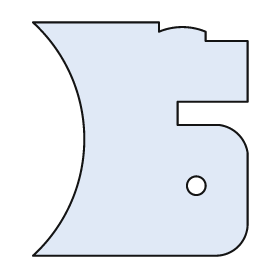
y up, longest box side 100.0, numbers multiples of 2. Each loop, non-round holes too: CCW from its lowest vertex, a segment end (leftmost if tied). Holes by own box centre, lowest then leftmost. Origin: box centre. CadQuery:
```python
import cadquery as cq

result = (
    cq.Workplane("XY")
    .moveTo(-46.0, -50.0)
    .lineTo(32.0, -50.0)
    .threePointArc((42.0, -46.0), (46.0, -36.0))
    .lineTo(46.0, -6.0)
    .threePointArc((42.0, 2.0), (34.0, 6.0))
    .lineTo(16.0, 6.0)
    .lineTo(16.0, 16.0)
    .lineTo(46.0, 16.0)
    .lineTo(46.0, 42.0)
    .lineTo(28.0, 42.0)
    .lineTo(28.0, 46.0)
    .threePointArc((18.0, 48.0), (8.0, 46.0))
    .lineTo(8.0, 50.0)
    .lineTo(-46.0, 50.0)
    .threePointArc((-24.0, 0.0), (-46.0, -50.0))
    .close()
    .moveTo(24.0, -20.0)
    .circle(4.0)
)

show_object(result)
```